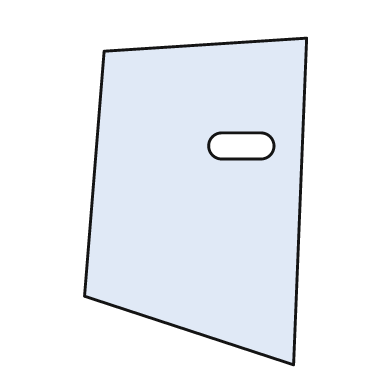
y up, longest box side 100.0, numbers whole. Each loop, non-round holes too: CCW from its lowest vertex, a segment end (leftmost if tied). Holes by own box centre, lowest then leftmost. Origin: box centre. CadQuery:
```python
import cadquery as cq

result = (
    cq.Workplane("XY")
    .moveTo(30.0, -50.0)
    .lineTo(34.0, 50.0)
    .lineTo(-28.0, 46.0)
    .lineTo(-34.0, -29.0)
    .close()
    .moveTo(8.0, 13.0)
    .lineTo(20.0, 13.0)
    .threePointArc((24.0, 17.0), (20.0, 21.0))
    .lineTo(8.0, 21.0)
    .threePointArc((4.0, 17.0), (8.0, 13.0))
    .close()
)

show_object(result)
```